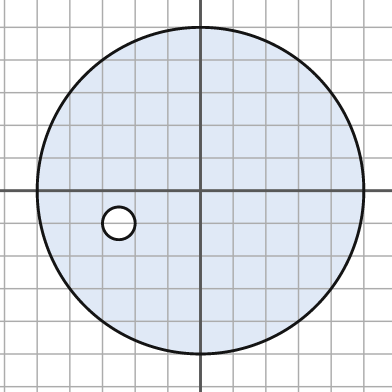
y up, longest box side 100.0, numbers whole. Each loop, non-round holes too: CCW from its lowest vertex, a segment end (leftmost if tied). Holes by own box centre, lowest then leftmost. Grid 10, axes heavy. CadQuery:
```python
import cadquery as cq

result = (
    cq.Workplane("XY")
    .moveTo(0.0, 0.0)
    .circle(50.0)
    .moveTo(-25.0, -10.0)
    .circle(5.0)
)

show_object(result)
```